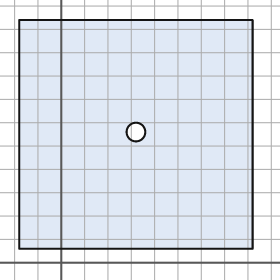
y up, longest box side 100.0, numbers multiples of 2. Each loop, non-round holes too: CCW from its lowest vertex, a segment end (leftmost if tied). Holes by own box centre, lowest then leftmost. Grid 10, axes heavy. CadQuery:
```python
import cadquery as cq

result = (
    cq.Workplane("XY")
    .moveTo(-18.0, 6.0)
    .lineTo(82.0, 6.0)
    .lineTo(82.0, 104.0)
    .lineTo(-18.0, 104.0)
    .close()
    .moveTo(32.0, 56.0)
    .circle(4.0)
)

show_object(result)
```